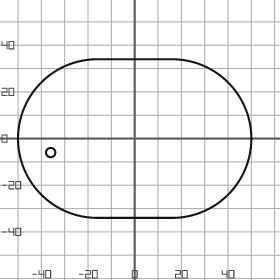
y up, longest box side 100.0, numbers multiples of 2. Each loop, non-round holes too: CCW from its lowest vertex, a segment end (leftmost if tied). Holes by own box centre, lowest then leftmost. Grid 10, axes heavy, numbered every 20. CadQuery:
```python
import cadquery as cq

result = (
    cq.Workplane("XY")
    .moveTo(-16.0, -34.0)
    .lineTo(16.0, -34.0)
    .threePointArc((50.0, 0.0), (16.0, 34.0))
    .lineTo(-16.0, 34.0)
    .threePointArc((-50.0, 0.0), (-16.0, -34.0))
    .close()
    .moveTo(-36.0, -6.0)
    .circle(2.0)
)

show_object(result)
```